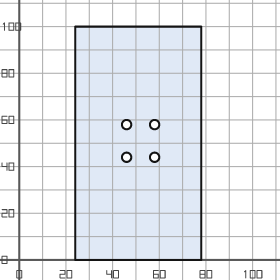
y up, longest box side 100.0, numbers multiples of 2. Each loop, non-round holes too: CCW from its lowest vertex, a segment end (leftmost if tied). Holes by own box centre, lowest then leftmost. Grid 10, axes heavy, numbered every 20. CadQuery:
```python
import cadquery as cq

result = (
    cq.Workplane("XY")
    .moveTo(24.0, 0.0)
    .lineTo(78.0, 0.0)
    .lineTo(78.0, 100.0)
    .lineTo(24.0, 100.0)
    .close()
    .moveTo(46.0, 44.0)
    .circle(2.0)
    .moveTo(58.0, 44.0)
    .circle(2.0)
    .moveTo(46.0, 58.0)
    .circle(2.0)
    .moveTo(58.0, 58.0)
    .circle(2.0)
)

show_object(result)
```